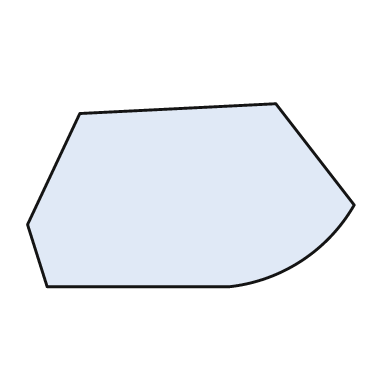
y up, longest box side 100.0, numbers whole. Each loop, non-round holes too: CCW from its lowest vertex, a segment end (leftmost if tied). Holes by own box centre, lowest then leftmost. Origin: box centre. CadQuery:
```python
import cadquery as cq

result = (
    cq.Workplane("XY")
    .moveTo(-44.0, -28.0)
    .lineTo(12.0, -28.0)
    .threePointArc((34.0, -20.0), (50.0, -3.0))
    .lineTo(26.0, 28.0)
    .lineTo(-34.0, 25.0)
    .lineTo(-50.0, -9.0)
    .close()
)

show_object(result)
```